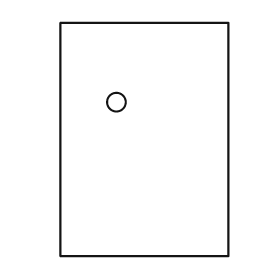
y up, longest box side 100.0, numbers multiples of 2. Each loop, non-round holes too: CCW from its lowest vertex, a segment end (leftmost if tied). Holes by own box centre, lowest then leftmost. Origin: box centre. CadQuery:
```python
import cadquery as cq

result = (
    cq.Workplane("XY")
    .moveTo(-36.0, -50.0)
    .lineTo(36.0, -50.0)
    .lineTo(36.0, 50.0)
    .lineTo(-36.0, 50.0)
    .close()
    .moveTo(-12.0, 16.0)
    .circle(4.0)
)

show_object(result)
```